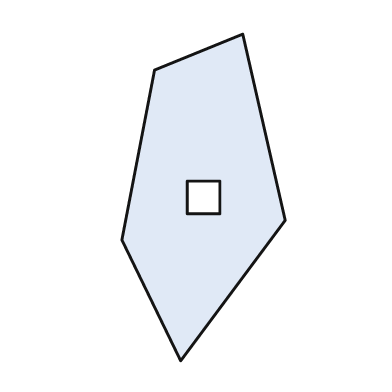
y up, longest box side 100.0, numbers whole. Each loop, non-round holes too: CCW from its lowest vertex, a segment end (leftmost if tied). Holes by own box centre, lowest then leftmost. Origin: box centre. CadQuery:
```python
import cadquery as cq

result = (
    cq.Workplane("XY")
    .moveTo(-7.0, -50.0)
    .lineTo(25.0, -7.0)
    .lineTo(12.0, 50.0)
    .lineTo(-15.0, 39.0)
    .lineTo(-25.0, -13.0)
    .close()
    .moveTo(-5.0, -5.0)
    .lineTo(5.0, -5.0)
    .lineTo(5.0, 5.0)
    .lineTo(-5.0, 5.0)
    .close()
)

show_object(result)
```